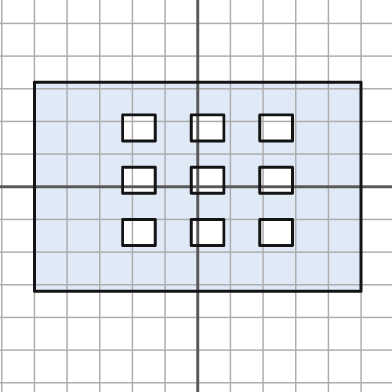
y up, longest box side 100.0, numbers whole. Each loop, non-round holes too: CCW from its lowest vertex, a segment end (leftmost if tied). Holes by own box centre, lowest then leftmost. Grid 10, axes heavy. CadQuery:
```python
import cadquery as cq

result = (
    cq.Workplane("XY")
    .moveTo(-50.0, -32.0)
    .lineTo(50.0, -32.0)
    .lineTo(50.0, 32.0)
    .lineTo(-50.0, 32.0)
    .close()
    .moveTo(-23.0, -18.0)
    .lineTo(-13.0, -18.0)
    .lineTo(-13.0, -10.0)
    .lineTo(-23.0, -10.0)
    .close()
    .moveTo(-2.0, -18.0)
    .lineTo(8.0, -18.0)
    .lineTo(8.0, -10.0)
    .lineTo(-2.0, -10.0)
    .close()
    .moveTo(19.0, -18.0)
    .lineTo(29.0, -18.0)
    .lineTo(29.0, -10.0)
    .lineTo(19.0, -10.0)
    .close()
    .moveTo(-23.0, -2.0)
    .lineTo(-13.0, -2.0)
    .lineTo(-13.0, 6.0)
    .lineTo(-23.0, 6.0)
    .close()
    .moveTo(-2.0, -2.0)
    .lineTo(8.0, -2.0)
    .lineTo(8.0, 6.0)
    .lineTo(-2.0, 6.0)
    .close()
    .moveTo(19.0, -2.0)
    .lineTo(29.0, -2.0)
    .lineTo(29.0, 6.0)
    .lineTo(19.0, 6.0)
    .close()
    .moveTo(-23.0, 14.0)
    .lineTo(-13.0, 14.0)
    .lineTo(-13.0, 22.0)
    .lineTo(-23.0, 22.0)
    .close()
    .moveTo(-2.0, 14.0)
    .lineTo(8.0, 14.0)
    .lineTo(8.0, 22.0)
    .lineTo(-2.0, 22.0)
    .close()
    .moveTo(19.0, 14.0)
    .lineTo(29.0, 14.0)
    .lineTo(29.0, 22.0)
    .lineTo(19.0, 22.0)
    .close()
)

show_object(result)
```